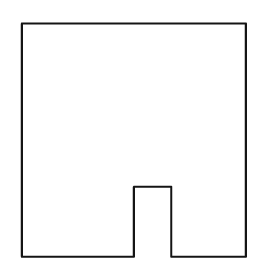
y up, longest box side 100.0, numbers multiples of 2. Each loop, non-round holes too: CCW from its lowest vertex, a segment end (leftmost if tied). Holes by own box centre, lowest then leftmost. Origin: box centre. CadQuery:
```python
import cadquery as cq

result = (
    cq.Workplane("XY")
    .moveTo(-48.0, -50.0)
    .lineTo(0.0, -50.0)
    .lineTo(0.0, -20.0)
    .lineTo(16.0, -20.0)
    .lineTo(16.0, -50.0)
    .lineTo(48.0, -50.0)
    .lineTo(48.0, 50.0)
    .lineTo(-48.0, 50.0)
    .close()
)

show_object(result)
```